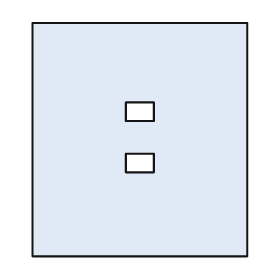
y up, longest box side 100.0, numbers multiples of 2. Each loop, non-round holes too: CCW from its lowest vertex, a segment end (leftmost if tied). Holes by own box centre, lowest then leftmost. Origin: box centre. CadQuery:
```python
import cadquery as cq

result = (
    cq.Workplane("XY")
    .moveTo(-46.0, -50.0)
    .lineTo(46.0, -50.0)
    .lineTo(46.0, 50.0)
    .lineTo(-46.0, 50.0)
    .close()
    .moveTo(-6.0, -14.0)
    .lineTo(6.0, -14.0)
    .lineTo(6.0, -6.0)
    .lineTo(-6.0, -6.0)
    .close()
    .moveTo(-6.0, 8.0)
    .lineTo(6.0, 8.0)
    .lineTo(6.0, 16.0)
    .lineTo(-6.0, 16.0)
    .close()
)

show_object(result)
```